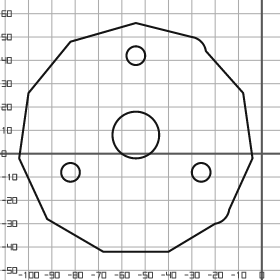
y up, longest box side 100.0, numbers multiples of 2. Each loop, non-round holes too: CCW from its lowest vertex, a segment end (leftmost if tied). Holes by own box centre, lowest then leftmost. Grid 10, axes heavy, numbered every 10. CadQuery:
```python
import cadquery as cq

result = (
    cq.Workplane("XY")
    .moveTo(-68.0, -42.0)
    .lineTo(-40.0, -42.0)
    .lineTo(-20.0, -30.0)
    .threePointArc((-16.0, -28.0), (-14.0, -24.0))
    .lineTo(-4.0, -2.0)
    .lineTo(-8.0, 26.0)
    .lineTo(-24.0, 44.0)
    .threePointArc((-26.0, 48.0), (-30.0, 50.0))
    .lineTo(-54.0, 56.0)
    .lineTo(-82.0, 48.0)
    .lineTo(-100.0, 26.0)
    .lineTo(-104.0, -2.0)
    .lineTo(-92.0, -28.0)
    .close()
    .moveTo(-82.0, -8.0)
    .circle(4.0)
    .moveTo(-26.0, -8.0)
    .circle(4.0)
    .moveTo(-54.0, 8.0)
    .circle(10.0)
    .moveTo(-54.0, 42.0)
    .circle(4.0)
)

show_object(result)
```